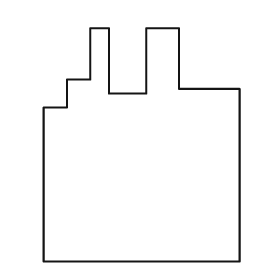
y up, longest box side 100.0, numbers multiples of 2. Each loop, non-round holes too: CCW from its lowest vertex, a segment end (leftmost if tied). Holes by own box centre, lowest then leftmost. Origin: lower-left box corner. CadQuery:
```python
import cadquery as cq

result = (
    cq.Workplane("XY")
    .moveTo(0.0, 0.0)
    .lineTo(84.0, 0.0)
    .lineTo(84.0, 74.0)
    .lineTo(58.0, 74.0)
    .lineTo(58.0, 100.0)
    .lineTo(44.0, 100.0)
    .lineTo(44.0, 72.0)
    .lineTo(28.0, 72.0)
    .lineTo(28.0, 100.0)
    .lineTo(20.0, 100.0)
    .lineTo(20.0, 78.0)
    .lineTo(10.0, 78.0)
    .lineTo(10.0, 66.0)
    .lineTo(0.0, 66.0)
    .close()
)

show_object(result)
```